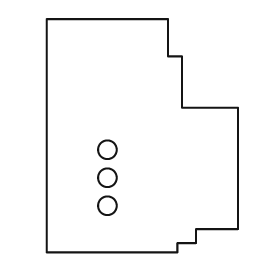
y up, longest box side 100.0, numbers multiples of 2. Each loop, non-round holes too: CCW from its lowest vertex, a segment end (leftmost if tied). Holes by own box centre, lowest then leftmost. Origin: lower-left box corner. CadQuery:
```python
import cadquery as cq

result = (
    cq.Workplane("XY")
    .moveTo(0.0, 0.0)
    .lineTo(56.0, 0.0)
    .lineTo(56.0, 4.0)
    .lineTo(64.0, 4.0)
    .lineTo(64.0, 10.0)
    .lineTo(82.0, 10.0)
    .lineTo(82.0, 62.0)
    .lineTo(58.0, 62.0)
    .lineTo(58.0, 84.0)
    .lineTo(52.0, 84.0)
    .lineTo(52.0, 100.0)
    .lineTo(0.0, 100.0)
    .close()
    .moveTo(26.0, 20.0)
    .circle(4.0)
    .moveTo(26.0, 32.0)
    .circle(4.0)
    .moveTo(26.0, 44.0)
    .circle(4.0)
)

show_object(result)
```